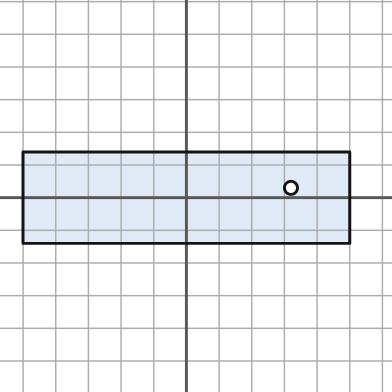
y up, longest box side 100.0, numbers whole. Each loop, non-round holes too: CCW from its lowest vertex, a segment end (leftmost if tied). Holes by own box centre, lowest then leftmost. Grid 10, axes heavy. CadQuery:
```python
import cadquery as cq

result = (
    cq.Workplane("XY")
    .moveTo(-50.0, -14.0)
    .lineTo(50.0, -14.0)
    .lineTo(50.0, 14.0)
    .lineTo(-50.0, 14.0)
    .close()
    .moveTo(32.0, 3.0)
    .circle(2.0)
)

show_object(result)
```